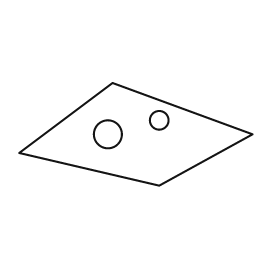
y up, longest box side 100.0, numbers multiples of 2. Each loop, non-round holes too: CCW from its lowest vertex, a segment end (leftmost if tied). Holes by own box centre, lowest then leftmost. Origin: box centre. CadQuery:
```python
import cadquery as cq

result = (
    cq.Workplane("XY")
    .moveTo(10.0, -22.0)
    .lineTo(50.0, 0.0)
    .lineTo(-10.0, 22.0)
    .lineTo(-50.0, -8.0)
    .close()
    .moveTo(-12.0, 0.0)
    .circle(6.0)
    .moveTo(10.0, 6.0)
    .circle(4.0)
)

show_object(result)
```